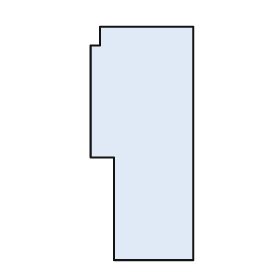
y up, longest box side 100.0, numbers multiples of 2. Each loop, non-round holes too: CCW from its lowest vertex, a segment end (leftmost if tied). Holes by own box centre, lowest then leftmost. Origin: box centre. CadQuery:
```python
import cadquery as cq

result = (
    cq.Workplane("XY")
    .moveTo(-12.0, -50.0)
    .lineTo(22.0, -50.0)
    .lineTo(22.0, 50.0)
    .lineTo(-18.0, 50.0)
    .lineTo(-18.0, 42.0)
    .lineTo(-22.0, 42.0)
    .lineTo(-22.0, -6.0)
    .lineTo(-12.0, -6.0)
    .close()
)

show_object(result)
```